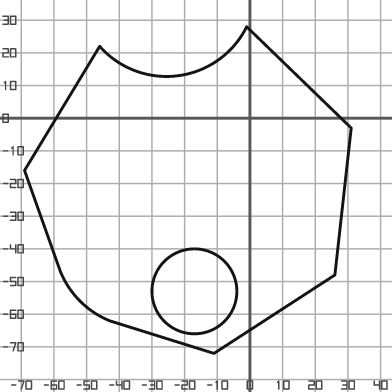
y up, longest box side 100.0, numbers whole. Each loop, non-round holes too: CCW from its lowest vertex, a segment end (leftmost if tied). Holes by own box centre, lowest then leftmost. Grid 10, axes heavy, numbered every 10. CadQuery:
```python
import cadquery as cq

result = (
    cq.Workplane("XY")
    .moveTo(-11.0, -72.0)
    .lineTo(26.0, -48.0)
    .lineTo(31.0, -3.0)
    .lineTo(-1.0, 28.0)
    .threePointArc((-22.0, 13.0), (-46.0, 22.0))
    .lineTo(-69.0, -16.0)
    .lineTo(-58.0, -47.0)
    .threePointArc((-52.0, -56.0), (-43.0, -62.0))
    .close()
    .moveTo(-17.0, -53.0)
    .circle(13.0)
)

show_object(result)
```